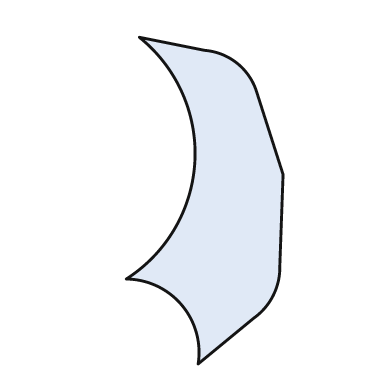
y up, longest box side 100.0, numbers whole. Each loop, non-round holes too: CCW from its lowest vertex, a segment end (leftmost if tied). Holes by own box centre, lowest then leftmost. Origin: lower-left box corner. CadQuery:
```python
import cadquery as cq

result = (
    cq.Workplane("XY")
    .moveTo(22.0, 0.0)
    .lineTo(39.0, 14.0)
    .threePointArc((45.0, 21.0), (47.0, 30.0))
    .lineTo(48.0, 58.0)
    .lineTo(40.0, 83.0)
    .threePointArc((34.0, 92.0), (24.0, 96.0))
    .lineTo(4.0, 100.0)
    .threePointArc((21.0, 62.0), (0.0, 26.0))
    .threePointArc((17.0, 18.0), (22.0, 0.0))
    .close()
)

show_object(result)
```